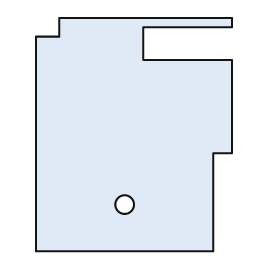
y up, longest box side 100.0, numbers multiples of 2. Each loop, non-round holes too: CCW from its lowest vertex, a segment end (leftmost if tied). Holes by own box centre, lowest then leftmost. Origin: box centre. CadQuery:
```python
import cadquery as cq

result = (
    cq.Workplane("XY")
    .moveTo(-42.0, -50.0)
    .lineTo(34.0, -50.0)
    .lineTo(34.0, -8.0)
    .lineTo(42.0, -8.0)
    .lineTo(42.0, 32.0)
    .lineTo(4.0, 32.0)
    .lineTo(4.0, 46.0)
    .lineTo(42.0, 46.0)
    .lineTo(42.0, 50.0)
    .lineTo(-32.0, 50.0)
    .lineTo(-32.0, 42.0)
    .lineTo(-42.0, 42.0)
    .close()
    .moveTo(-4.0, -30.0)
    .circle(4.0)
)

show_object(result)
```